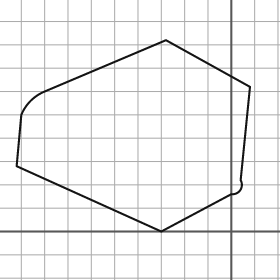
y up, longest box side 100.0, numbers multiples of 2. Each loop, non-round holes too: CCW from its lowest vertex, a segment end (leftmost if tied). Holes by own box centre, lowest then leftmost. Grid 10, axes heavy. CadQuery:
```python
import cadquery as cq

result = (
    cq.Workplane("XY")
    .moveTo(-30.0, 0.0)
    .lineTo(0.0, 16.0)
    .threePointArc((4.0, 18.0), (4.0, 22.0))
    .lineTo(8.0, 62.0)
    .lineTo(-28.0, 82.0)
    .lineTo(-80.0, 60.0)
    .threePointArc((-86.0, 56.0), (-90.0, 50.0))
    .lineTo(-92.0, 28.0)
    .close()
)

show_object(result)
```